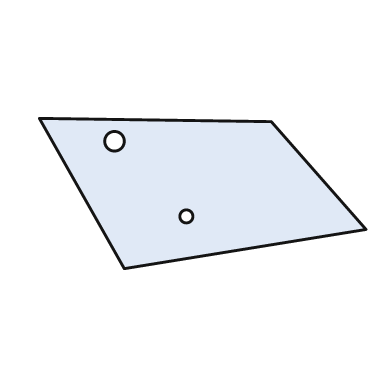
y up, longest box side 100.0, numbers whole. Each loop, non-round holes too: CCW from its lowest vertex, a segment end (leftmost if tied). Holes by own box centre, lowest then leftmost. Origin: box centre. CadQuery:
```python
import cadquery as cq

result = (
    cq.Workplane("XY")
    .moveTo(-24.0, -23.0)
    .lineTo(50.0, -11.0)
    .lineTo(21.0, 22.0)
    .lineTo(-50.0, 23.0)
    .close()
    .moveTo(-5.0, -7.0)
    .circle(2.0)
    .moveTo(-27.0, 16.0)
    .circle(3.0)
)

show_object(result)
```